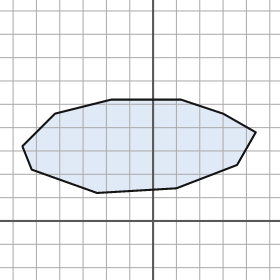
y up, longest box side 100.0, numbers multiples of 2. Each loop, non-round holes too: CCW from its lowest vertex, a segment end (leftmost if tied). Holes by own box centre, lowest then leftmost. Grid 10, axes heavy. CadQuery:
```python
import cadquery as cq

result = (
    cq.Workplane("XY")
    .moveTo(-24.0, 12.0)
    .lineTo(10.0, 14.0)
    .lineTo(36.0, 24.0)
    .lineTo(44.0, 38.0)
    .lineTo(30.0, 46.0)
    .lineTo(12.0, 52.0)
    .lineTo(-18.0, 52.0)
    .lineTo(-42.0, 46.0)
    .lineTo(-56.0, 32.0)
    .lineTo(-52.0, 22.0)
    .close()
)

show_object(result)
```